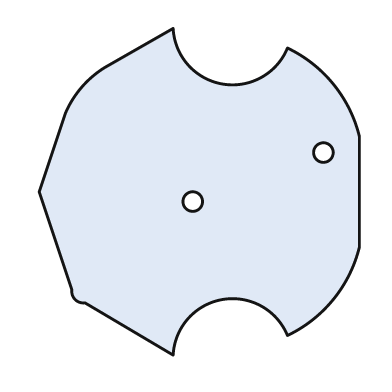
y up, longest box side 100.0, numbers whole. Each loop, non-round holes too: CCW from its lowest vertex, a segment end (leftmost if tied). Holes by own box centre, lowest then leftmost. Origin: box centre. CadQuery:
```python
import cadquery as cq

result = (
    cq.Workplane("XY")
    .moveTo(-8.0, -50.0)
    .threePointArc((7.0, -33.0), (27.0, -44.0))
    .threePointArc((41.0, -33.0), (49.0, -17.0))
    .lineTo(49.0, 17.0)
    .threePointArc((41.0, 33.0), (27.0, 44.0))
    .threePointArc((7.0, 33.0), (-8.0, 50.0))
    .lineTo(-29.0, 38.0)
    .threePointArc((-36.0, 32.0), (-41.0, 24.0))
    .lineTo(-49.0, 0.0)
    .lineTo(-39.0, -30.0)
    .threePointArc((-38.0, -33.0), (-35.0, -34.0))
    .close()
    .moveTo(-2.0, -3.0)
    .circle(3.0)
    .moveTo(38.0, 12.0)
    .circle(3.0)
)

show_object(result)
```